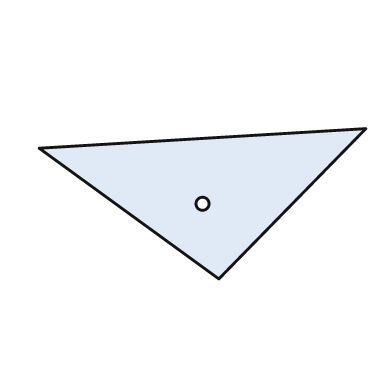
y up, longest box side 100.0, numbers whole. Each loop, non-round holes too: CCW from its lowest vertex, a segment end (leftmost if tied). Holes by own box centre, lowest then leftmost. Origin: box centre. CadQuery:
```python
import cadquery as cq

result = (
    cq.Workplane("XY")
    .moveTo(5.0, -23.0)
    .lineTo(50.0, 23.0)
    .lineTo(-50.0, 17.0)
    .close()
    .moveTo(0.0, 0.0)
    .circle(2.0)
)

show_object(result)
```